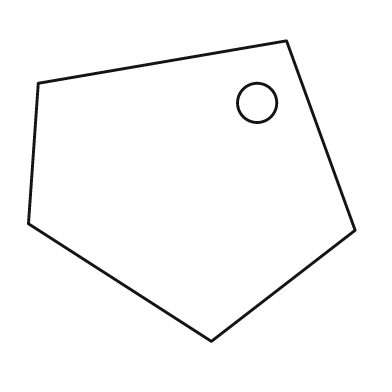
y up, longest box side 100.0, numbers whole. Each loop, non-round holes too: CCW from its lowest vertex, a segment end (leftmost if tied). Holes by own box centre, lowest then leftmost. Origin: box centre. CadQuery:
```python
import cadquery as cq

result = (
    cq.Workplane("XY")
    .moveTo(6.0, -46.0)
    .lineTo(50.0, -12.0)
    .lineTo(29.0, 46.0)
    .lineTo(-47.0, 33.0)
    .lineTo(-50.0, -10.0)
    .close()
    .moveTo(20.0, 27.0)
    .circle(6.0)
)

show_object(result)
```